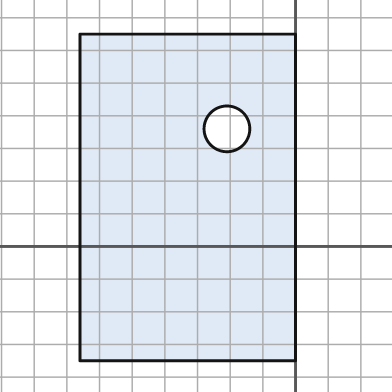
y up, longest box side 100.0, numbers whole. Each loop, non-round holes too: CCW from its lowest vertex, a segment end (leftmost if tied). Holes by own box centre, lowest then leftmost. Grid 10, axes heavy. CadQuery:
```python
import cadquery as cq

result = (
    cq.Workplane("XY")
    .moveTo(-66.0, -35.0)
    .lineTo(0.0, -35.0)
    .lineTo(0.0, 65.0)
    .lineTo(-66.0, 65.0)
    .close()
    .moveTo(-21.0, 36.0)
    .circle(7.0)
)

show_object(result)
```